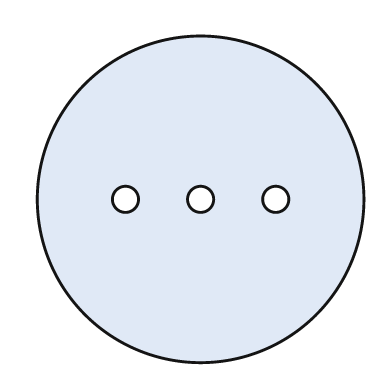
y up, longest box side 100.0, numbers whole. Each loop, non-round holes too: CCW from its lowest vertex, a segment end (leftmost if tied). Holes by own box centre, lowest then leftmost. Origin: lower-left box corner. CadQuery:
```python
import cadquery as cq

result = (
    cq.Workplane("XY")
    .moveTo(50.0, 50.0)
    .circle(50.0)
    .moveTo(27.0, 50.0)
    .circle(4.0)
    .moveTo(50.0, 50.0)
    .circle(4.0)
    .moveTo(73.0, 50.0)
    .circle(4.0)
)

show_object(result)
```